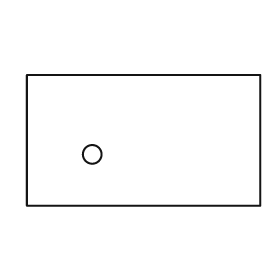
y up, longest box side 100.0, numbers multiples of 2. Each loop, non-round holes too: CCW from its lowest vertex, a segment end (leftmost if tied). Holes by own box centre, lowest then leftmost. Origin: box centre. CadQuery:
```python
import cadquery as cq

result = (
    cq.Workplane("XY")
    .moveTo(-50.0, -28.0)
    .lineTo(50.0, -28.0)
    .lineTo(50.0, 28.0)
    .lineTo(-50.0, 28.0)
    .close()
    .moveTo(-22.0, -6.0)
    .circle(4.0)
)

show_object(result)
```